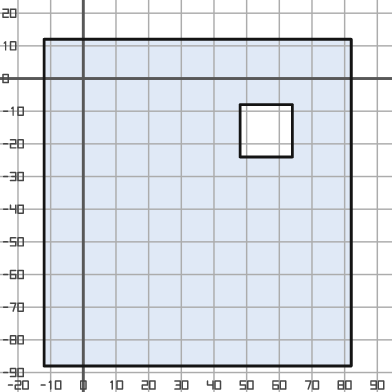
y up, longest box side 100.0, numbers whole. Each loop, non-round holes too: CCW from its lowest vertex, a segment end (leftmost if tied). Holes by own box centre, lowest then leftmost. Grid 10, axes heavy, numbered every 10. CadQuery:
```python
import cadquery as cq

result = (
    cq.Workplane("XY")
    .moveTo(-12.0, -88.0)
    .lineTo(82.0, -88.0)
    .lineTo(82.0, 12.0)
    .lineTo(-12.0, 12.0)
    .close()
    .moveTo(48.0, -24.0)
    .lineTo(64.0, -24.0)
    .lineTo(64.0, -8.0)
    .lineTo(48.0, -8.0)
    .close()
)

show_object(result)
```